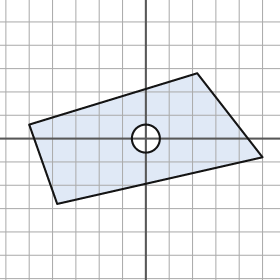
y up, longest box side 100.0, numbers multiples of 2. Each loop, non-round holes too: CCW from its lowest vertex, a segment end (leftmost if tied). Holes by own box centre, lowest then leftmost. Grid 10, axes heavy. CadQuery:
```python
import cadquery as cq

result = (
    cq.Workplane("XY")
    .moveTo(-38.0, -28.0)
    .lineTo(50.0, -8.0)
    .lineTo(22.0, 28.0)
    .lineTo(-50.0, 6.0)
    .close()
    .moveTo(0.0, 0.0)
    .circle(6.0)
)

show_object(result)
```